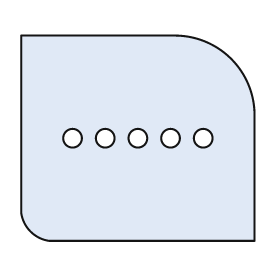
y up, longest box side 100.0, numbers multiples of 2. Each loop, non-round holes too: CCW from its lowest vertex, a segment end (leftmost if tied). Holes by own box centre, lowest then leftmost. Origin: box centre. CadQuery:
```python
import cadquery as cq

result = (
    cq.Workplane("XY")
    .moveTo(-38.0, -44.0)
    .lineTo(50.0, -44.0)
    .lineTo(50.0, 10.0)
    .threePointArc((40.0, 34.0), (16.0, 44.0))
    .lineTo(-50.0, 44.0)
    .lineTo(-50.0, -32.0)
    .threePointArc((-46.0, -40.0), (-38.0, -44.0))
    .close()
    .moveTo(-28.0, 0.0)
    .circle(4.0)
    .moveTo(-14.0, 0.0)
    .circle(4.0)
    .moveTo(0.0, 0.0)
    .circle(4.0)
    .moveTo(14.0, 0.0)
    .circle(4.0)
    .moveTo(28.0, 0.0)
    .circle(4.0)
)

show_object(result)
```